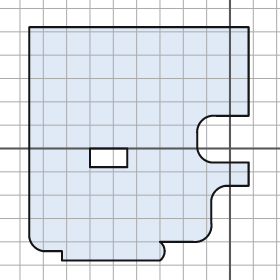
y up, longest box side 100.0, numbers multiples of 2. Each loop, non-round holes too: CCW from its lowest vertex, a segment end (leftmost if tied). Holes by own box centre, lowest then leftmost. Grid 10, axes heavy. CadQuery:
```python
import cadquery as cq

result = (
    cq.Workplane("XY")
    .moveTo(-72.0, -48.0)
    .lineTo(-30.0, -48.0)
    .threePointArc((-28.0, -44.0), (-30.0, -40.0))
    .lineTo(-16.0, -40.0)
    .threePointArc((-10.0, -38.0), (-8.0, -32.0))
    .lineTo(-8.0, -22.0)
    .threePointArc((-6.0, -18.0), (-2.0, -16.0))
    .lineTo(8.0, -16.0)
    .lineTo(8.0, -6.0)
    .lineTo(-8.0, -6.0)
    .threePointArc((-12.0, -4.0), (-14.0, 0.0))
    .lineTo(-14.0, 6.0)
    .threePointArc((-12.0, 12.0), (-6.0, 14.0))
    .lineTo(8.0, 14.0)
    .lineTo(8.0, 52.0)
    .lineTo(-86.0, 52.0)
    .lineTo(-86.0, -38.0)
    .threePointArc((-84.0, -42.0), (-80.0, -44.0))
    .lineTo(-72.0, -44.0)
    .close()
    .moveTo(-60.0, -8.0)
    .lineTo(-44.0, -8.0)
    .lineTo(-44.0, 0.0)
    .lineTo(-60.0, 0.0)
    .close()
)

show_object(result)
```